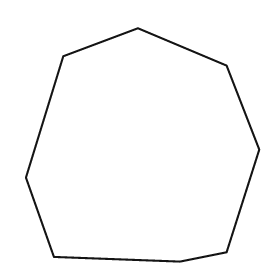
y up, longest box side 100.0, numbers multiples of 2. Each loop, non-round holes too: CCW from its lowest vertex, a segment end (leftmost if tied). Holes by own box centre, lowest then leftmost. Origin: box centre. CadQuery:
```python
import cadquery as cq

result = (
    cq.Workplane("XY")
    .moveTo(16.0, -50.0)
    .lineTo(36.0, -46.0)
    .lineTo(50.0, -2.0)
    .lineTo(36.0, 34.0)
    .lineTo(-2.0, 50.0)
    .lineTo(-34.0, 38.0)
    .lineTo(-50.0, -14.0)
    .lineTo(-38.0, -48.0)
    .close()
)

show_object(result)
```